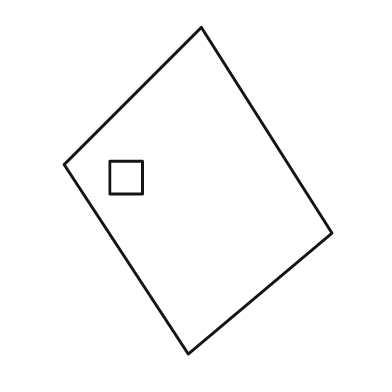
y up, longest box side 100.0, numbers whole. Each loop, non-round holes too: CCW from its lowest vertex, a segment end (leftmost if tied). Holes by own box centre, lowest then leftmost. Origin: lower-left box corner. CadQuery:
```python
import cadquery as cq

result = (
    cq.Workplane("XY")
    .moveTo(38.0, 0.0)
    .lineTo(82.0, 37.0)
    .lineTo(42.0, 100.0)
    .lineTo(0.0, 58.0)
    .close()
    .moveTo(14.0, 49.0)
    .lineTo(24.0, 49.0)
    .lineTo(24.0, 59.0)
    .lineTo(14.0, 59.0)
    .close()
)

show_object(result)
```